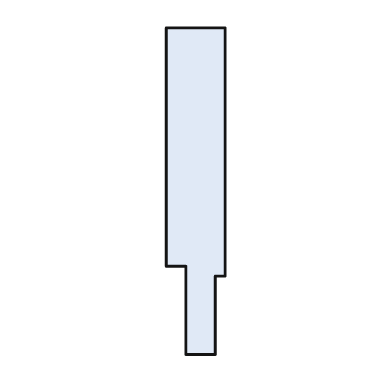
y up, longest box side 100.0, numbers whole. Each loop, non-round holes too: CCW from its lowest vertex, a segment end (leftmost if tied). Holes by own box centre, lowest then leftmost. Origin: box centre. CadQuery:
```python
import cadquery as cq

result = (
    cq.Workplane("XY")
    .moveTo(-3.0, -50.0)
    .lineTo(6.0, -50.0)
    .lineTo(6.0, -26.0)
    .lineTo(9.0, -26.0)
    .lineTo(9.0, 50.0)
    .lineTo(-9.0, 50.0)
    .lineTo(-9.0, -23.0)
    .lineTo(-3.0, -23.0)
    .close()
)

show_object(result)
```